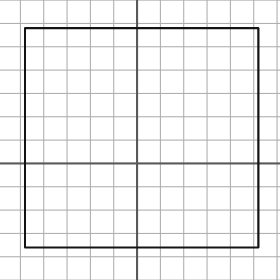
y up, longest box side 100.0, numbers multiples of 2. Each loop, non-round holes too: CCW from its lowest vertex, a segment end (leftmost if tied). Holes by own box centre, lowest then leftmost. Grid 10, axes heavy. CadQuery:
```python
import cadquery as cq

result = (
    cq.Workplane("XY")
    .moveTo(-48.0, -36.0)
    .lineTo(52.0, -36.0)
    .lineTo(52.0, 58.0)
    .lineTo(-48.0, 58.0)
    .close()
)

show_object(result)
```